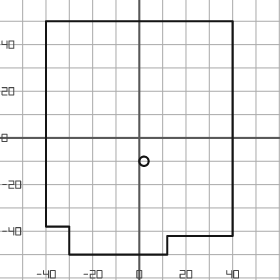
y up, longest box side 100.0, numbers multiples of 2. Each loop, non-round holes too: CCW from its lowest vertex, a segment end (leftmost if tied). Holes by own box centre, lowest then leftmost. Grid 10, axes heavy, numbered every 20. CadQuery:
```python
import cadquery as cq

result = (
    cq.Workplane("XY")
    .moveTo(-30.0, -50.0)
    .lineTo(12.0, -50.0)
    .lineTo(12.0, -42.0)
    .lineTo(40.0, -42.0)
    .lineTo(40.0, 50.0)
    .lineTo(-40.0, 50.0)
    .lineTo(-40.0, -38.0)
    .lineTo(-30.0, -38.0)
    .close()
    .moveTo(2.0, -10.0)
    .circle(2.0)
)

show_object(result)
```